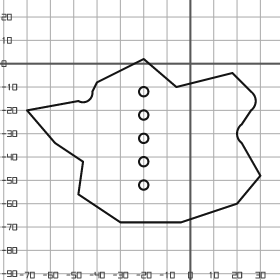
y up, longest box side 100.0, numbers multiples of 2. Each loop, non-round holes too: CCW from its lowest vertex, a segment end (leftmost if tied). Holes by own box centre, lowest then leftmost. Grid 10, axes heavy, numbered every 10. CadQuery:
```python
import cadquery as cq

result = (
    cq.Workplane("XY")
    .moveTo(-30.0, -68.0)
    .lineTo(-4.0, -68.0)
    .lineTo(20.0, -60.0)
    .lineTo(30.0, -48.0)
    .lineTo(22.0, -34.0)
    .threePointArc((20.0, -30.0), (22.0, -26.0))
    .lineTo(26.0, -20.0)
    .threePointArc((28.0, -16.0), (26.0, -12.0))
    .lineTo(18.0, -4.0)
    .lineTo(-6.0, -10.0)
    .lineTo(-20.0, 2.0)
    .lineTo(-40.0, -8.0)
    .lineTo(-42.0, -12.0)
    .threePointArc((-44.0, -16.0), (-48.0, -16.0))
    .lineTo(-70.0, -20.0)
    .lineTo(-58.0, -34.0)
    .lineTo(-46.0, -42.0)
    .lineTo(-48.0, -56.0)
    .close()
    .moveTo(-20.0, -52.0)
    .circle(2.0)
    .moveTo(-20.0, -42.0)
    .circle(2.0)
    .moveTo(-20.0, -32.0)
    .circle(2.0)
    .moveTo(-20.0, -22.0)
    .circle(2.0)
    .moveTo(-20.0, -12.0)
    .circle(2.0)
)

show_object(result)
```